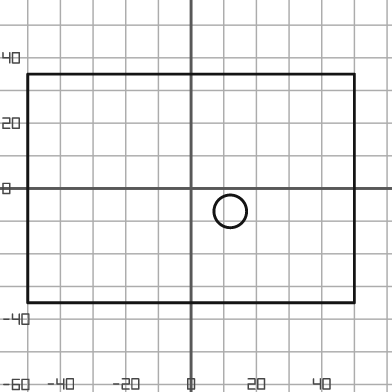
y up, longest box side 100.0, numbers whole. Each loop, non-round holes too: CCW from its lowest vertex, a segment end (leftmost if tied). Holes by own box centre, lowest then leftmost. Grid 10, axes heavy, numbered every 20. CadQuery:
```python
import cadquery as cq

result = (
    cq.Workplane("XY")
    .moveTo(-50.0, -35.0)
    .lineTo(50.0, -35.0)
    .lineTo(50.0, 35.0)
    .lineTo(-50.0, 35.0)
    .close()
    .moveTo(12.0, -7.0)
    .circle(5.0)
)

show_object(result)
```